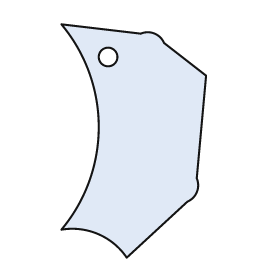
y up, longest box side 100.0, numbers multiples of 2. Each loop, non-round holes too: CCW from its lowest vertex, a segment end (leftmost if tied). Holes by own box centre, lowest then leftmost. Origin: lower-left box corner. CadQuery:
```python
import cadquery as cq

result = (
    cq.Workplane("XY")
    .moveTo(28.0, 0.0)
    .lineTo(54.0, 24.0)
    .threePointArc((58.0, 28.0), (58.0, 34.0))
    .lineTo(62.0, 78.0)
    .lineTo(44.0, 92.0)
    .threePointArc((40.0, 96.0), (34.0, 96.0))
    .lineTo(0.0, 100.0)
    .threePointArc((16.0, 56.0), (0.0, 12.0))
    .threePointArc((16.0, 10.0), (28.0, 0.0))
    .close()
    .moveTo(20.0, 86.0)
    .circle(4.0)
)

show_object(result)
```